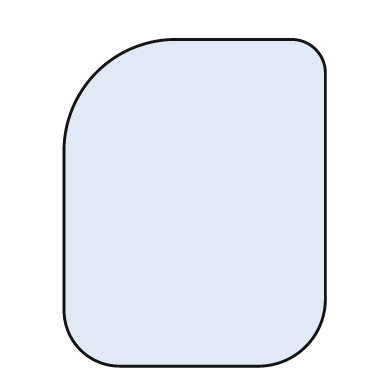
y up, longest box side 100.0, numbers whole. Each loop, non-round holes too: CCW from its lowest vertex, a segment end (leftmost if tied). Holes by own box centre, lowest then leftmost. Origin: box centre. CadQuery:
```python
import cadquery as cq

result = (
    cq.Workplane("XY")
    .moveTo(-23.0, -50.0)
    .lineTo(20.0, -50.0)
    .threePointArc((34.0, -44.0), (40.0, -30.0))
    .lineTo(40.0, 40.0)
    .threePointArc((37.0, 47.0), (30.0, 50.0))
    .lineTo(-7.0, 50.0)
    .threePointArc((-30.0, 40.0), (-40.0, 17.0))
    .lineTo(-40.0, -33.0)
    .threePointArc((-35.0, -45.0), (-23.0, -50.0))
    .close()
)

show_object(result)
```